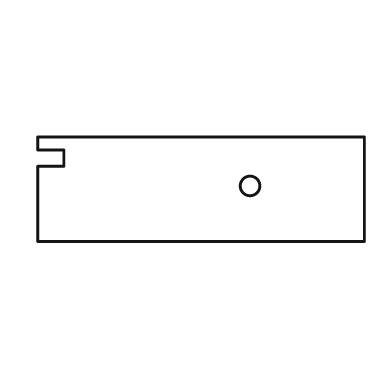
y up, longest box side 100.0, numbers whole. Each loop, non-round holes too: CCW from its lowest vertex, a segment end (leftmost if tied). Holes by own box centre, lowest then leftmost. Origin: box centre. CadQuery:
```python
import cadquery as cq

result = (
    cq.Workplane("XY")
    .moveTo(-50.0, -16.0)
    .lineTo(50.0, -16.0)
    .lineTo(50.0, 16.0)
    .lineTo(-50.0, 16.0)
    .lineTo(-50.0, 12.0)
    .lineTo(-42.0, 12.0)
    .lineTo(-42.0, 7.0)
    .lineTo(-50.0, 7.0)
    .close()
    .moveTo(15.0, 1.0)
    .circle(3.0)
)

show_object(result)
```